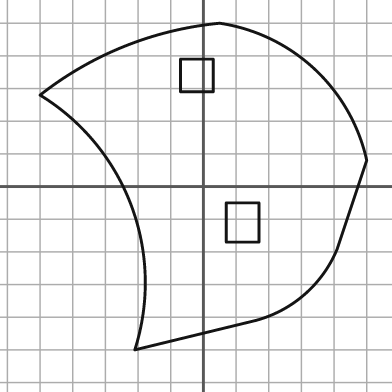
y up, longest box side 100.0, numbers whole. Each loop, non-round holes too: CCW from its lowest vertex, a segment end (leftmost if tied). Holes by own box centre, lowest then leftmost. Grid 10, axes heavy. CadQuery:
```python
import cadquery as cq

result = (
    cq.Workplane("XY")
    .moveTo(-21.0, -50.0)
    .lineTo(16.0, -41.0)
    .threePointArc((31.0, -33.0), (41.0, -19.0))
    .lineTo(50.0, 8.0)
    .threePointArc((34.0, 36.0), (5.0, 50.0))
    .threePointArc((-24.0, 43.0), (-50.0, 28.0))
    .threePointArc((-22.0, -6.0), (-21.0, -50.0))
    .close()
    .moveTo(7.0, -17.0)
    .lineTo(17.0, -17.0)
    .lineTo(17.0, -5.0)
    .lineTo(7.0, -5.0)
    .close()
    .moveTo(-7.0, 29.0)
    .lineTo(3.0, 29.0)
    .lineTo(3.0, 39.0)
    .lineTo(-7.0, 39.0)
    .close()
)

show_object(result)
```